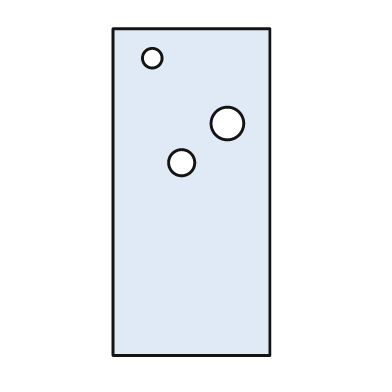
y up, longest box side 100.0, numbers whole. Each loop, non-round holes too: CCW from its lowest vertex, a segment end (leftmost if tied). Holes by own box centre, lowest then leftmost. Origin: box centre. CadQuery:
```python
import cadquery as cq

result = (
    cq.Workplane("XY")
    .moveTo(-24.0, -50.0)
    .lineTo(24.0, -50.0)
    .lineTo(24.0, 50.0)
    .lineTo(-24.0, 50.0)
    .close()
    .moveTo(-3.0, 9.0)
    .circle(4.0)
    .moveTo(11.0, 21.0)
    .circle(5.0)
    .moveTo(-12.0, 41.0)
    .circle(3.0)
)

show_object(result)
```